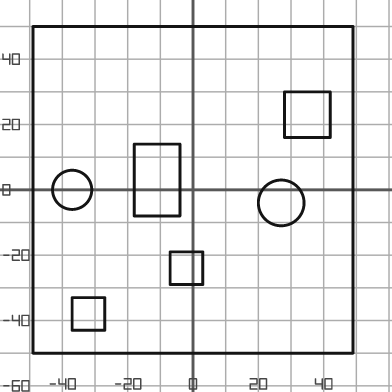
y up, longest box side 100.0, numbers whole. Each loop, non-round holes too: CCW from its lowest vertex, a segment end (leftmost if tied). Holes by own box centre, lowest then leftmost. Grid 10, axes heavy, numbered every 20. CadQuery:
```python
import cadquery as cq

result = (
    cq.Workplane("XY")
    .moveTo(-49.0, -50.0)
    .lineTo(49.0, -50.0)
    .lineTo(49.0, 50.0)
    .lineTo(-49.0, 50.0)
    .close()
    .moveTo(-37.0, -43.0)
    .lineTo(-27.0, -43.0)
    .lineTo(-27.0, -33.0)
    .lineTo(-37.0, -33.0)
    .close()
    .moveTo(-7.0, -29.0)
    .lineTo(3.0, -29.0)
    .lineTo(3.0, -19.0)
    .lineTo(-7.0, -19.0)
    .close()
    .moveTo(27.0, -4.0)
    .circle(7.0)
    .moveTo(-37.0, 0.0)
    .circle(6.0)
    .moveTo(-18.0, -8.0)
    .lineTo(-4.0, -8.0)
    .lineTo(-4.0, 14.0)
    .lineTo(-18.0, 14.0)
    .close()
    .moveTo(28.0, 16.0)
    .lineTo(42.0, 16.0)
    .lineTo(42.0, 30.0)
    .lineTo(28.0, 30.0)
    .close()
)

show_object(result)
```